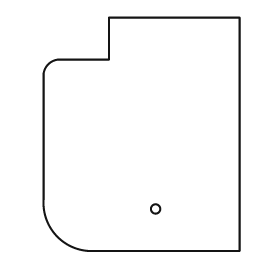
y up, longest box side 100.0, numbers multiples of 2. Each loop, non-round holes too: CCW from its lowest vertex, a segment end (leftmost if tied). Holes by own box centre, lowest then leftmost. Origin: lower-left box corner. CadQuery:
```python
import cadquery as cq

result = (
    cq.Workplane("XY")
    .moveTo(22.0, 0.0)
    .lineTo(84.0, 0.0)
    .lineTo(84.0, 100.0)
    .lineTo(28.0, 100.0)
    .lineTo(28.0, 82.0)
    .lineTo(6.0, 82.0)
    .threePointArc((2.0, 80.0), (0.0, 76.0))
    .lineTo(0.0, 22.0)
    .threePointArc((6.0, 6.0), (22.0, 0.0))
    .close()
    .moveTo(48.0, 18.0)
    .circle(2.0)
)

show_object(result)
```